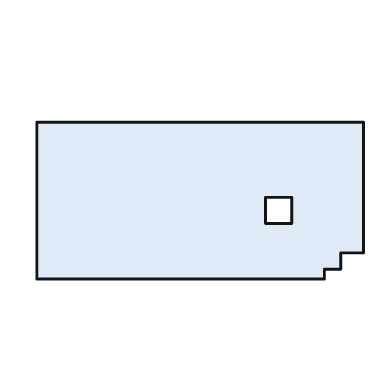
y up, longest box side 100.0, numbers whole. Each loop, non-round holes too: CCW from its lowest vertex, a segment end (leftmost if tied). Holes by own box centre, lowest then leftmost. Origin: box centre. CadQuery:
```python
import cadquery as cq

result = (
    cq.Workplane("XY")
    .moveTo(-50.0, -24.0)
    .lineTo(38.0, -24.0)
    .lineTo(38.0, -21.0)
    .lineTo(43.0, -21.0)
    .lineTo(43.0, -16.0)
    .lineTo(50.0, -16.0)
    .lineTo(50.0, 24.0)
    .lineTo(-50.0, 24.0)
    .close()
    .moveTo(20.0, -7.0)
    .lineTo(28.0, -7.0)
    .lineTo(28.0, 1.0)
    .lineTo(20.0, 1.0)
    .close()
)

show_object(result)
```